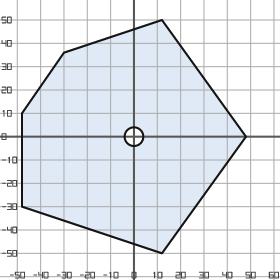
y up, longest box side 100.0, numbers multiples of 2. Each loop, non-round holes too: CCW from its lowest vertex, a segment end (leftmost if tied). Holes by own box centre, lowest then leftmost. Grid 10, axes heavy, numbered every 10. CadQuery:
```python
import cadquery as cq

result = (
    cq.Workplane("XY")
    .moveTo(12.0, -50.0)
    .lineTo(48.0, 0.0)
    .lineTo(12.0, 50.0)
    .lineTo(-30.0, 36.0)
    .lineTo(-48.0, 10.0)
    .lineTo(-48.0, -30.0)
    .close()
    .moveTo(0.0, 0.0)
    .circle(4.0)
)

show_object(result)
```